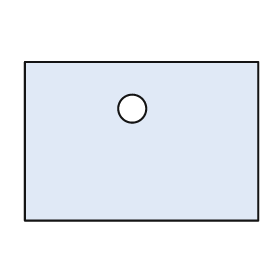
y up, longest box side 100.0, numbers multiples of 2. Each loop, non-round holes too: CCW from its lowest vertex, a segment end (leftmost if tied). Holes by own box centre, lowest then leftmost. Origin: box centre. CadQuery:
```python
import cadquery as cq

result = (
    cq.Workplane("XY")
    .moveTo(-50.0, -34.0)
    .lineTo(50.0, -34.0)
    .lineTo(50.0, 34.0)
    .lineTo(-50.0, 34.0)
    .close()
    .moveTo(-4.0, 14.0)
    .circle(6.0)
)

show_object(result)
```